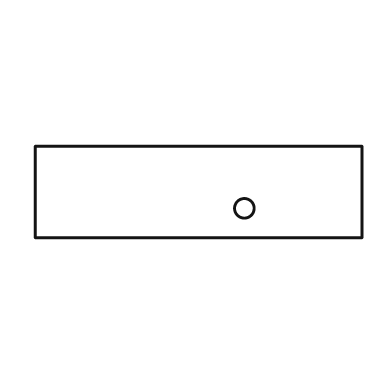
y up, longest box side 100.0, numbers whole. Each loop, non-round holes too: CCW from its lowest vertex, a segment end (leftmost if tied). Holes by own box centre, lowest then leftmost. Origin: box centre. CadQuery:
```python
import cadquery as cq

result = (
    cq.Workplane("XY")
    .moveTo(-50.0, -14.0)
    .lineTo(50.0, -14.0)
    .lineTo(50.0, 14.0)
    .lineTo(-50.0, 14.0)
    .close()
    .moveTo(14.0, -5.0)
    .circle(3.0)
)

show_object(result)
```